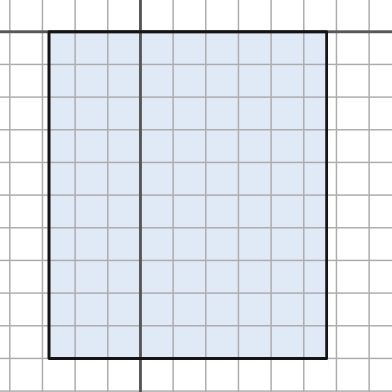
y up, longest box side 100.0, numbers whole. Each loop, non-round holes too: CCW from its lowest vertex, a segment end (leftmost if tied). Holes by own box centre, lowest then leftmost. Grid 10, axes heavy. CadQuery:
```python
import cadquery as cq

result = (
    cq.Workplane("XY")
    .moveTo(-28.0, -100.0)
    .lineTo(57.0, -100.0)
    .lineTo(57.0, 0.0)
    .lineTo(-28.0, 0.0)
    .close()
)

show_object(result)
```